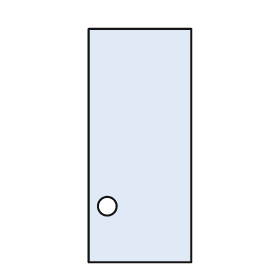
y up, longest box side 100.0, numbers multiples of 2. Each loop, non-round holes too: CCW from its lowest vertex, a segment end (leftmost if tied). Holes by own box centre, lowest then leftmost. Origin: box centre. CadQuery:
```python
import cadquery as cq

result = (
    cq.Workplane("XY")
    .moveTo(-22.0, -50.0)
    .lineTo(22.0, -50.0)
    .lineTo(22.0, 50.0)
    .lineTo(-22.0, 50.0)
    .close()
    .moveTo(-14.0, -26.0)
    .circle(4.0)
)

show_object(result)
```